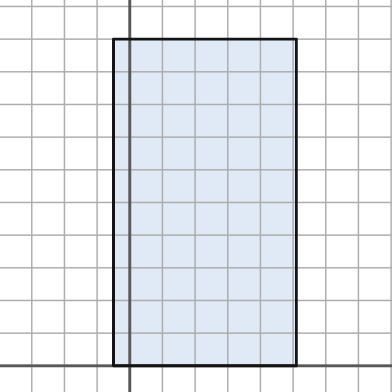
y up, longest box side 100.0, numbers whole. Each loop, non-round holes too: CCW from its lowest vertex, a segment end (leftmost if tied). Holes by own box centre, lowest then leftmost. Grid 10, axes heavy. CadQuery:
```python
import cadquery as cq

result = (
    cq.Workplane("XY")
    .moveTo(-5.0, 0.0)
    .lineTo(51.0, 0.0)
    .lineTo(51.0, 100.0)
    .lineTo(-5.0, 100.0)
    .close()
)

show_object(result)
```